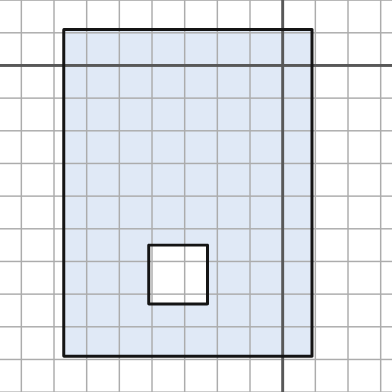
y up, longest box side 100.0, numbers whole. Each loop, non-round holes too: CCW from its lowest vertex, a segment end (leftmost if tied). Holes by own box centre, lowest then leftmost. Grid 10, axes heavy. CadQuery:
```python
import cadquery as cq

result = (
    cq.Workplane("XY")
    .moveTo(-67.0, -89.0)
    .lineTo(9.0, -89.0)
    .lineTo(9.0, 11.0)
    .lineTo(-67.0, 11.0)
    .close()
    .moveTo(-41.0, -73.0)
    .lineTo(-23.0, -73.0)
    .lineTo(-23.0, -55.0)
    .lineTo(-41.0, -55.0)
    .close()
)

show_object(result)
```